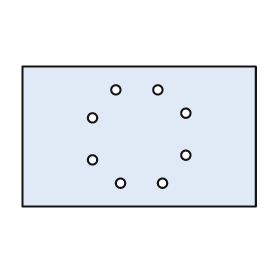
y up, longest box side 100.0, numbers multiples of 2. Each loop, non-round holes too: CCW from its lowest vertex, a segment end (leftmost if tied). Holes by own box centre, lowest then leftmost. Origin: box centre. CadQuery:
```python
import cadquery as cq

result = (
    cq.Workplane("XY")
    .moveTo(-50.0, -30.0)
    .lineTo(50.0, -30.0)
    .lineTo(50.0, 30.0)
    .lineTo(-50.0, 30.0)
    .close()
    .moveTo(-8.0, -20.0)
    .circle(2.0)
    .moveTo(10.0, -20.0)
    .circle(2.0)
    .moveTo(-20.0, -10.0)
    .circle(2.0)
    .moveTo(20.0, -8.0)
    .circle(2.0)
    .moveTo(-20.0, 8.0)
    .circle(2.0)
    .moveTo(20.0, 10.0)
    .circle(2.0)
    .moveTo(-10.0, 20.0)
    .circle(2.0)
    .moveTo(8.0, 20.0)
    .circle(2.0)
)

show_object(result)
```